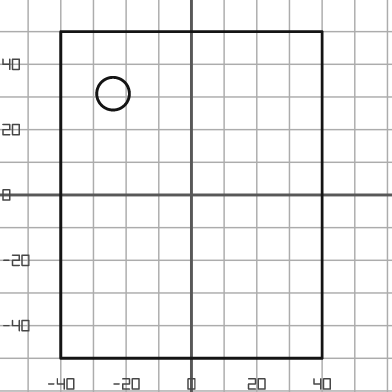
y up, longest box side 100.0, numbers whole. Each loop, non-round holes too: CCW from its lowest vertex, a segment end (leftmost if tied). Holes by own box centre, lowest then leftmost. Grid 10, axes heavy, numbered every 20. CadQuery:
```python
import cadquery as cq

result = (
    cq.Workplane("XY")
    .moveTo(-40.0, -50.0)
    .lineTo(40.0, -50.0)
    .lineTo(40.0, 50.0)
    .lineTo(-40.0, 50.0)
    .close()
    .moveTo(-24.0, 31.0)
    .circle(5.0)
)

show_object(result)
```